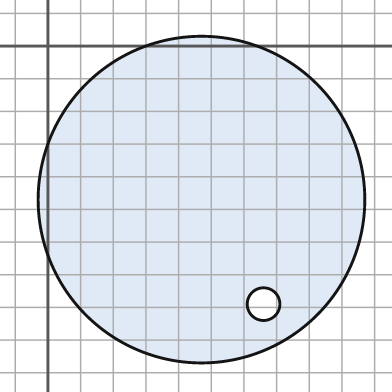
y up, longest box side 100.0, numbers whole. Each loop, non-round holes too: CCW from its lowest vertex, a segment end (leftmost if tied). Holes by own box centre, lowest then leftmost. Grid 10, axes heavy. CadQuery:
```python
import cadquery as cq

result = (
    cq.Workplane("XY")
    .moveTo(47.0, -47.0)
    .circle(50.0)
    .moveTo(66.0, -79.0)
    .circle(5.0)
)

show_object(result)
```